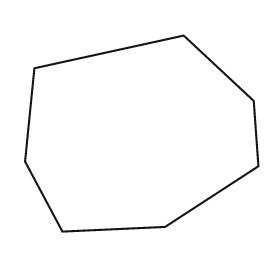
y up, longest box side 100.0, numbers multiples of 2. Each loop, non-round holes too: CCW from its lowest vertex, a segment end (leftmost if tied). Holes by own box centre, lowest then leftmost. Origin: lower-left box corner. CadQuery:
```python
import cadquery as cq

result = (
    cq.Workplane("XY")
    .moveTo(16.0, 0.0)
    .lineTo(60.0, 2.0)
    .lineTo(100.0, 28.0)
    .lineTo(98.0, 56.0)
    .lineTo(68.0, 84.0)
    .lineTo(4.0, 70.0)
    .lineTo(0.0, 30.0)
    .close()
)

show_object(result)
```